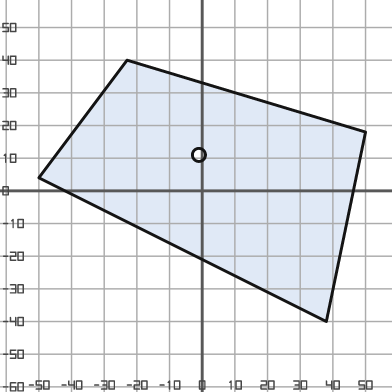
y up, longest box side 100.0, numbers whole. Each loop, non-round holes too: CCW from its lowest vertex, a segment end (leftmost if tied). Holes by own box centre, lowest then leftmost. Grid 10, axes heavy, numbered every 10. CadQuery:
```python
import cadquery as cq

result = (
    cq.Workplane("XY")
    .moveTo(38.0, -40.0)
    .lineTo(50.0, 18.0)
    .lineTo(-23.0, 40.0)
    .lineTo(-50.0, 4.0)
    .close()
    .moveTo(-1.0, 11.0)
    .circle(2.0)
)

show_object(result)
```